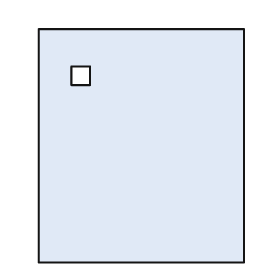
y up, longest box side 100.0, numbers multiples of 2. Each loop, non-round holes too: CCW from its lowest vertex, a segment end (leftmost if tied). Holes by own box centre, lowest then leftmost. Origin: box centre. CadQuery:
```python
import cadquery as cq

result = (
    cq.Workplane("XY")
    .moveTo(-44.0, -50.0)
    .lineTo(44.0, -50.0)
    .lineTo(44.0, 50.0)
    .lineTo(-44.0, 50.0)
    .close()
    .moveTo(-30.0, 26.0)
    .lineTo(-22.0, 26.0)
    .lineTo(-22.0, 34.0)
    .lineTo(-30.0, 34.0)
    .close()
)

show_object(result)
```